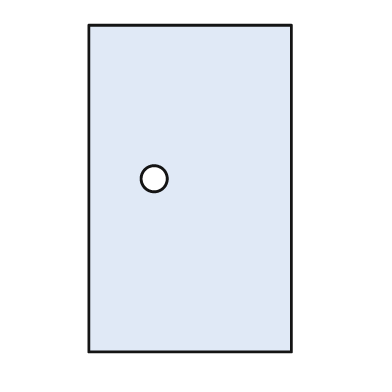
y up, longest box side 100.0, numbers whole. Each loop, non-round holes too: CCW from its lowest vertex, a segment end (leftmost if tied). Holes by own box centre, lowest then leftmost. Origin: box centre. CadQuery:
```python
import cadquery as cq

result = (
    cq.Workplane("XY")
    .moveTo(-31.0, -50.0)
    .lineTo(31.0, -50.0)
    .lineTo(31.0, 50.0)
    .lineTo(-31.0, 50.0)
    .close()
    .moveTo(-11.0, 3.0)
    .circle(4.0)
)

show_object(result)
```